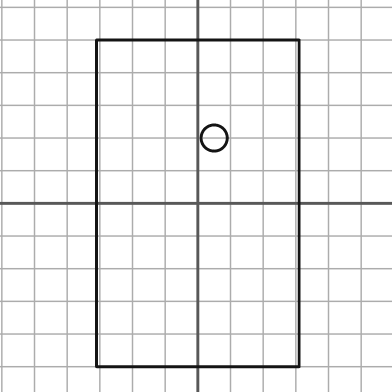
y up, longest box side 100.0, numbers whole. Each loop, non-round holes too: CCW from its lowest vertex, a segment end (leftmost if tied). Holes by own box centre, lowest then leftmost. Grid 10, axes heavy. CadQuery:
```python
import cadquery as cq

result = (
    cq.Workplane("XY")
    .moveTo(-31.0, -50.0)
    .lineTo(31.0, -50.0)
    .lineTo(31.0, 50.0)
    .lineTo(-31.0, 50.0)
    .close()
    .moveTo(5.0, 20.0)
    .circle(4.0)
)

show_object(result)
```